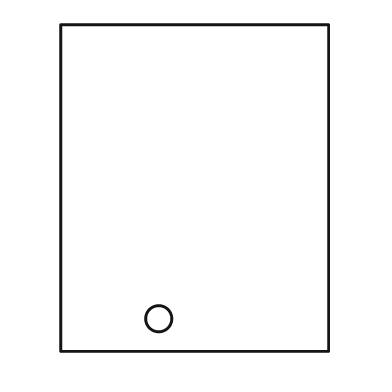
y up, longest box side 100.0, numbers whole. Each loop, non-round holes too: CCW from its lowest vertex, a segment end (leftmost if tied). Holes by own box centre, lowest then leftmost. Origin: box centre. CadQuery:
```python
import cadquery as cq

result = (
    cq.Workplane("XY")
    .moveTo(-41.0, -50.0)
    .lineTo(41.0, -50.0)
    .lineTo(41.0, 50.0)
    .lineTo(-41.0, 50.0)
    .close()
    .moveTo(-11.0, -40.0)
    .circle(4.0)
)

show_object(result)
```